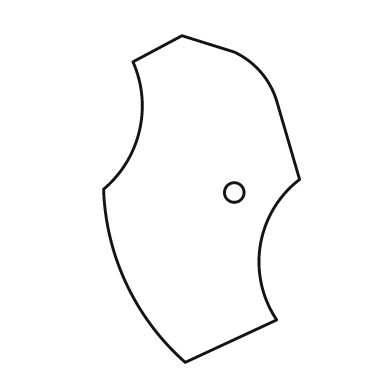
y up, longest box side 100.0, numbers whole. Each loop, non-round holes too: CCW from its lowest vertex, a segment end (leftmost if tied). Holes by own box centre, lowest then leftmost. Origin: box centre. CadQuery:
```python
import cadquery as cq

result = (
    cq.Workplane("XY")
    .moveTo(-5.0, -50.0)
    .lineTo(23.0, -37.0)
    .threePointArc((18.0, -14.0), (30.0, 6.0))
    .lineTo(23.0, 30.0)
    .threePointArc((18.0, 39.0), (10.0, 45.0))
    .lineTo(-6.0, 50.0)
    .lineTo(-21.0, 42.0)
    .threePointArc((-19.0, 21.0), (-30.0, 3.0))
    .threePointArc((-23.0, -26.0), (-5.0, -50.0))
    .close()
    .moveTo(10.0, 2.0)
    .circle(3.0)
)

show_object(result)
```